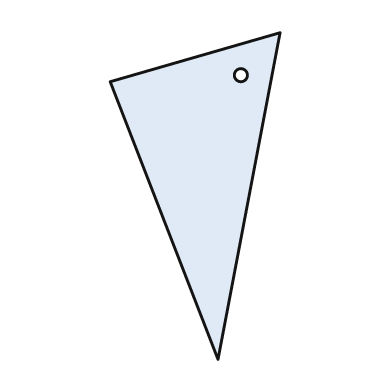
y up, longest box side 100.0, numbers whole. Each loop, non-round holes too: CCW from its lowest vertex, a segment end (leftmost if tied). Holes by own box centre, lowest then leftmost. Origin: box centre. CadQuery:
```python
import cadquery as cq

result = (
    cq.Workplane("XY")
    .moveTo(7.0, -50.0)
    .lineTo(26.0, 50.0)
    .lineTo(-26.0, 35.0)
    .close()
    .moveTo(14.0, 37.0)
    .circle(2.0)
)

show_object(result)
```